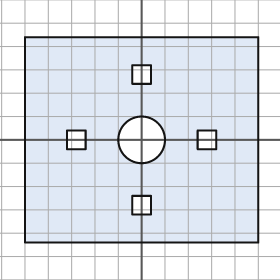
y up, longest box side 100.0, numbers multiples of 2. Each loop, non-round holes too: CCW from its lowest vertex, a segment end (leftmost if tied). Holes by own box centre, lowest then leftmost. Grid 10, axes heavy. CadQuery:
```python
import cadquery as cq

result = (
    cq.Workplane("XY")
    .moveTo(-50.0, -44.0)
    .lineTo(50.0, -44.0)
    .lineTo(50.0, 44.0)
    .lineTo(-50.0, 44.0)
    .close()
    .moveTo(-4.0, -32.0)
    .lineTo(4.0, -32.0)
    .lineTo(4.0, -24.0)
    .lineTo(-4.0, -24.0)
    .close()
    .moveTo(-32.0, -4.0)
    .lineTo(-24.0, -4.0)
    .lineTo(-24.0, 4.0)
    .lineTo(-32.0, 4.0)
    .close()
    .moveTo(0.0, 0.0)
    .circle(10.0)
    .moveTo(24.0, -4.0)
    .lineTo(32.0, -4.0)
    .lineTo(32.0, 4.0)
    .lineTo(24.0, 4.0)
    .close()
    .moveTo(-4.0, 24.0)
    .lineTo(4.0, 24.0)
    .lineTo(4.0, 32.0)
    .lineTo(-4.0, 32.0)
    .close()
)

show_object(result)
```